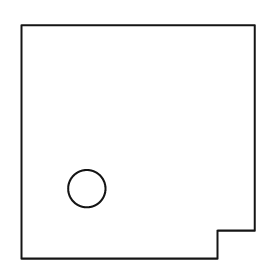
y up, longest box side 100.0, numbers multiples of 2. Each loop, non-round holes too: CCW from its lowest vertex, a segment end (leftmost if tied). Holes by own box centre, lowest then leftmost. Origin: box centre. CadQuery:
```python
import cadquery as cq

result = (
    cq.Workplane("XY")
    .moveTo(-50.0, -50.0)
    .lineTo(34.0, -50.0)
    .lineTo(34.0, -38.0)
    .lineTo(50.0, -38.0)
    .lineTo(50.0, 50.0)
    .lineTo(-50.0, 50.0)
    .close()
    .moveTo(-22.0, -20.0)
    .circle(8.0)
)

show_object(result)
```